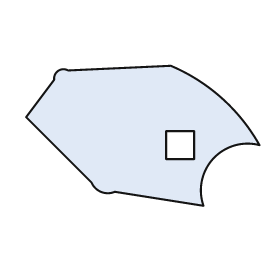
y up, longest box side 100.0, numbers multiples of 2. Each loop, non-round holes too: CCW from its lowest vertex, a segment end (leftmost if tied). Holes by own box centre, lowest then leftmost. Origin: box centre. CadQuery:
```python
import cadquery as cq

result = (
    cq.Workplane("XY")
    .moveTo(26.0, -30.0)
    .threePointArc((30.0, -10.0), (50.0, -4.0))
    .threePointArc((34.0, 16.0), (12.0, 30.0))
    .lineTo(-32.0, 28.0)
    .threePointArc((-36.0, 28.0), (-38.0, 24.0))
    .lineTo(-50.0, 8.0)
    .lineTo(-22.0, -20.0)
    .threePointArc((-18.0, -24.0), (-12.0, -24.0))
    .close()
    .moveTo(10.0, -10.0)
    .lineTo(22.0, -10.0)
    .lineTo(22.0, 2.0)
    .lineTo(10.0, 2.0)
    .close()
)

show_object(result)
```